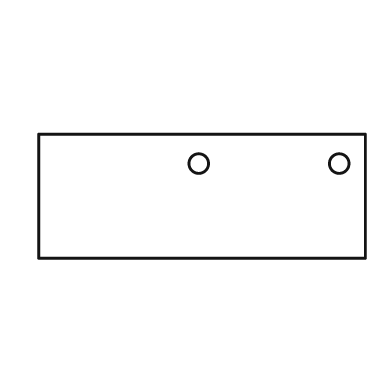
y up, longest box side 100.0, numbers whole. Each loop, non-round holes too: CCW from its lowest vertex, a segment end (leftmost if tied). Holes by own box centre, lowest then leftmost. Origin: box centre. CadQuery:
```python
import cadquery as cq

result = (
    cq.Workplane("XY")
    .moveTo(-50.0, -19.0)
    .lineTo(50.0, -19.0)
    .lineTo(50.0, 19.0)
    .lineTo(-50.0, 19.0)
    .close()
    .moveTo(-1.0, 10.0)
    .circle(3.0)
    .moveTo(42.0, 10.0)
    .circle(3.0)
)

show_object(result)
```